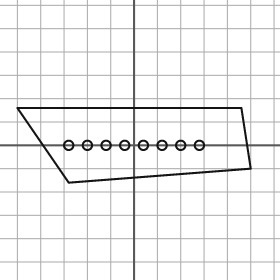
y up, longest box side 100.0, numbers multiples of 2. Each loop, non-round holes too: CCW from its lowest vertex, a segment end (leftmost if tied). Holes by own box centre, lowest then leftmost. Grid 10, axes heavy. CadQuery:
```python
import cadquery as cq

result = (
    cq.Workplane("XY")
    .moveTo(-28.0, -16.0)
    .lineTo(50.0, -10.0)
    .lineTo(46.0, 16.0)
    .lineTo(-50.0, 16.0)
    .close()
    .moveTo(-28.0, 0.0)
    .circle(2.0)
    .moveTo(-20.0, 0.0)
    .circle(2.0)
    .moveTo(-12.0, 0.0)
    .circle(2.0)
    .moveTo(-4.0, 0.0)
    .circle(2.0)
    .moveTo(4.0, 0.0)
    .circle(2.0)
    .moveTo(12.0, 0.0)
    .circle(2.0)
    .moveTo(20.0, 0.0)
    .circle(2.0)
    .moveTo(28.0, 0.0)
    .circle(2.0)
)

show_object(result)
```